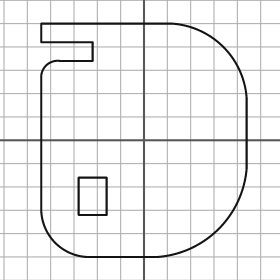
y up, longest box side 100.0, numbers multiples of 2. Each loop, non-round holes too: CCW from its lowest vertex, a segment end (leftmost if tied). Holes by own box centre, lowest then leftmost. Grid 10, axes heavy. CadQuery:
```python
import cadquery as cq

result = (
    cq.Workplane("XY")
    .moveTo(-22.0, -50.0)
    .lineTo(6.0, -50.0)
    .threePointArc((32.0, -38.0), (44.0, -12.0))
    .lineTo(44.0, 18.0)
    .threePointArc((34.0, 40.0), (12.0, 50.0))
    .lineTo(-44.0, 50.0)
    .lineTo(-44.0, 42.0)
    .lineTo(-22.0, 42.0)
    .lineTo(-22.0, 34.0)
    .lineTo(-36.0, 34.0)
    .threePointArc((-42.0, 32.0), (-44.0, 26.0))
    .lineTo(-44.0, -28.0)
    .threePointArc((-38.0, -44.0), (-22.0, -50.0))
    .close()
    .moveTo(-28.0, -32.0)
    .lineTo(-16.0, -32.0)
    .lineTo(-16.0, -16.0)
    .lineTo(-28.0, -16.0)
    .close()
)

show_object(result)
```